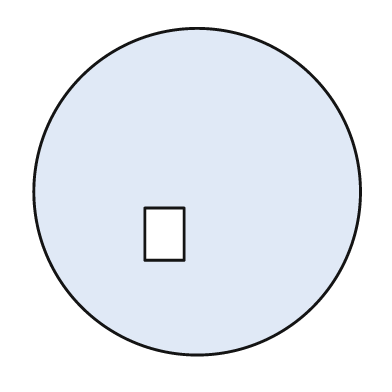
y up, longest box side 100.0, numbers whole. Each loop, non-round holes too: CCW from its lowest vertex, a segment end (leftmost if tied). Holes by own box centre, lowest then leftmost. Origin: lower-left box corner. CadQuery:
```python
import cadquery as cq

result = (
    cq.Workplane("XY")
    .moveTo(50.0, 50.0)
    .circle(50.0)
    .moveTo(34.0, 29.0)
    .lineTo(46.0, 29.0)
    .lineTo(46.0, 45.0)
    .lineTo(34.0, 45.0)
    .close()
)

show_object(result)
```